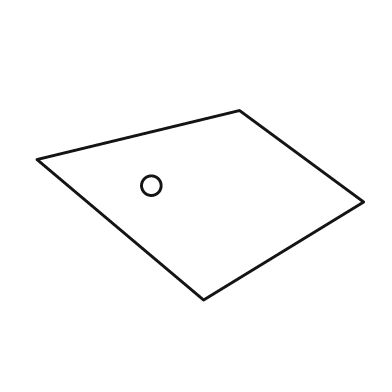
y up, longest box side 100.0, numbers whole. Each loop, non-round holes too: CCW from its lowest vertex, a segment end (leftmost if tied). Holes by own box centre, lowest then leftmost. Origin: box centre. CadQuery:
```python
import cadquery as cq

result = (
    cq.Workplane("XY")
    .moveTo(1.0, -29.0)
    .lineTo(50.0, 1.0)
    .lineTo(12.0, 29.0)
    .lineTo(-50.0, 14.0)
    .close()
    .moveTo(-15.0, 6.0)
    .circle(3.0)
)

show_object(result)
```